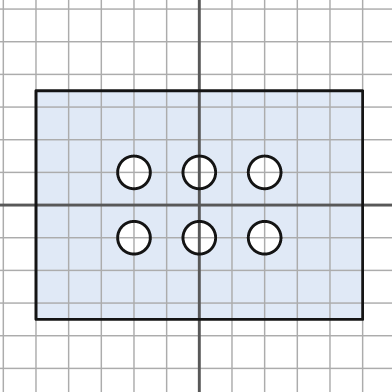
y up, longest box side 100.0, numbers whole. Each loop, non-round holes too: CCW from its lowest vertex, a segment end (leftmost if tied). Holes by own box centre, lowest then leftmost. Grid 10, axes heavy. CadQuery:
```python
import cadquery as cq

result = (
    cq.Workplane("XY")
    .moveTo(-50.0, -35.0)
    .lineTo(50.0, -35.0)
    .lineTo(50.0, 35.0)
    .lineTo(-50.0, 35.0)
    .close()
    .moveTo(-20.0, -10.0)
    .circle(5.0)
    .moveTo(0.0, -10.0)
    .circle(5.0)
    .moveTo(20.0, -10.0)
    .circle(5.0)
    .moveTo(-20.0, 10.0)
    .circle(5.0)
    .moveTo(0.0, 10.0)
    .circle(5.0)
    .moveTo(20.0, 10.0)
    .circle(5.0)
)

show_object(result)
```